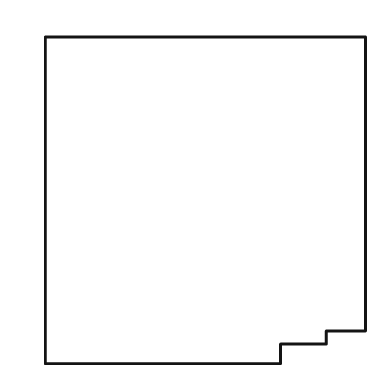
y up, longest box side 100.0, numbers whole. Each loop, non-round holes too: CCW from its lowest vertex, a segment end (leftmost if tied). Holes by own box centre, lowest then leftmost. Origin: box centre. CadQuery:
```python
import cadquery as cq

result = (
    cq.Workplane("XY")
    .moveTo(-49.0, -50.0)
    .lineTo(23.0, -50.0)
    .lineTo(23.0, -44.0)
    .lineTo(37.0, -44.0)
    .lineTo(37.0, -40.0)
    .lineTo(49.0, -40.0)
    .lineTo(49.0, 50.0)
    .lineTo(-49.0, 50.0)
    .close()
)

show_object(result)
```